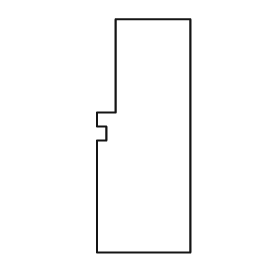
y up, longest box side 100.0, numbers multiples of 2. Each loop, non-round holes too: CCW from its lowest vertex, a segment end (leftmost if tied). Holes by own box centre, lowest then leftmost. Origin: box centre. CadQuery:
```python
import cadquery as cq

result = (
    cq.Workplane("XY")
    .moveTo(-20.0, -50.0)
    .lineTo(20.0, -50.0)
    .lineTo(20.0, 50.0)
    .lineTo(-12.0, 50.0)
    .lineTo(-12.0, 10.0)
    .lineTo(-20.0, 10.0)
    .lineTo(-20.0, 4.0)
    .lineTo(-16.0, 4.0)
    .lineTo(-16.0, -2.0)
    .lineTo(-20.0, -2.0)
    .close()
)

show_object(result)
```